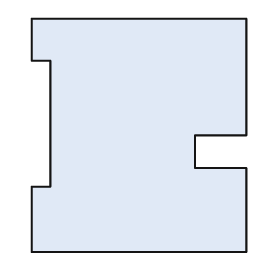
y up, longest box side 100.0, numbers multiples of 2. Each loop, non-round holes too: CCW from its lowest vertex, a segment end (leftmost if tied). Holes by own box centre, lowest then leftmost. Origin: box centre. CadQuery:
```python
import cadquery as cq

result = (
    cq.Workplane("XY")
    .moveTo(-46.0, -50.0)
    .lineTo(46.0, -50.0)
    .lineTo(46.0, -14.0)
    .lineTo(24.0, -14.0)
    .lineTo(24.0, 0.0)
    .lineTo(46.0, 0.0)
    .lineTo(46.0, 50.0)
    .lineTo(-46.0, 50.0)
    .lineTo(-46.0, 32.0)
    .lineTo(-38.0, 32.0)
    .lineTo(-38.0, -22.0)
    .lineTo(-46.0, -22.0)
    .close()
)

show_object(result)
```